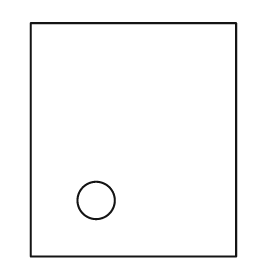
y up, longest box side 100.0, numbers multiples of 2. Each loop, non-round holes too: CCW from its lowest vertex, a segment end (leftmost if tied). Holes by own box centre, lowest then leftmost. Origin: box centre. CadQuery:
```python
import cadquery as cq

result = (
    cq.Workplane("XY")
    .moveTo(-44.0, -50.0)
    .lineTo(44.0, -50.0)
    .lineTo(44.0, 50.0)
    .lineTo(-44.0, 50.0)
    .close()
    .moveTo(-16.0, -26.0)
    .circle(8.0)
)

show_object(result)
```